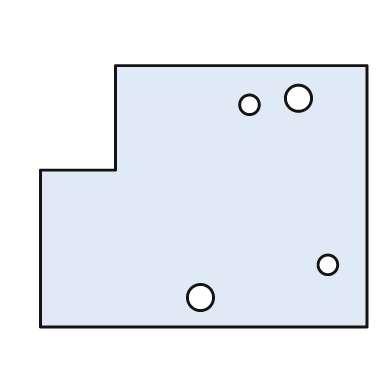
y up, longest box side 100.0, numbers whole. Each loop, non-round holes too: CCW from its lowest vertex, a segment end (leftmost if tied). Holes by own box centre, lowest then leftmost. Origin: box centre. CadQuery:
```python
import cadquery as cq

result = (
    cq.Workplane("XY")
    .moveTo(-50.0, -40.0)
    .lineTo(50.0, -40.0)
    .lineTo(50.0, 40.0)
    .lineTo(-27.0, 40.0)
    .lineTo(-27.0, 8.0)
    .lineTo(-50.0, 8.0)
    .close()
    .moveTo(-1.0, -31.0)
    .circle(4.0)
    .moveTo(38.0, -21.0)
    .circle(3.0)
    .moveTo(14.0, 28.0)
    .circle(3.0)
    .moveTo(29.0, 30.0)
    .circle(4.0)
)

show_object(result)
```